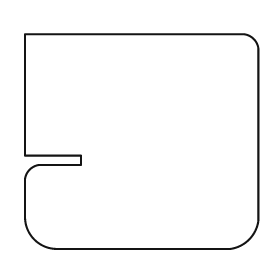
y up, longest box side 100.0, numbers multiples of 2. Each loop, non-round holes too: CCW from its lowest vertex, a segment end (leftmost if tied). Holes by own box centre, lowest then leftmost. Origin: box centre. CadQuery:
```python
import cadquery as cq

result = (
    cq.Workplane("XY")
    .moveTo(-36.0, -46.0)
    .lineTo(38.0, -46.0)
    .threePointArc((46.0, -42.0), (50.0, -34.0))
    .lineTo(50.0, 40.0)
    .threePointArc((48.0, 44.0), (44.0, 46.0))
    .lineTo(-50.0, 46.0)
    .lineTo(-50.0, -6.0)
    .lineTo(-26.0, -6.0)
    .lineTo(-26.0, -10.0)
    .lineTo(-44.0, -10.0)
    .threePointArc((-48.0, -12.0), (-50.0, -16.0))
    .lineTo(-50.0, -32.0)
    .threePointArc((-46.0, -42.0), (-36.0, -46.0))
    .close()
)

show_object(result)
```